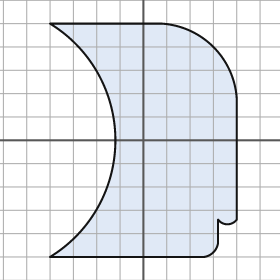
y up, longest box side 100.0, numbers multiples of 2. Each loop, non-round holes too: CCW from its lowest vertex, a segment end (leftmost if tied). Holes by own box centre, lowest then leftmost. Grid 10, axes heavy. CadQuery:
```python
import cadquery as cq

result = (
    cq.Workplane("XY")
    .moveTo(-40.0, -50.0)
    .lineTo(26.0, -50.0)
    .threePointArc((30.0, -48.0), (32.0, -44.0))
    .lineTo(32.0, -34.0)
    .threePointArc((36.0, -36.0), (40.0, -34.0))
    .lineTo(40.0, 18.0)
    .threePointArc((30.0, 40.0), (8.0, 50.0))
    .lineTo(-40.0, 50.0)
    .threePointArc((-12.0, 0.0), (-40.0, -50.0))
    .close()
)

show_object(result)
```